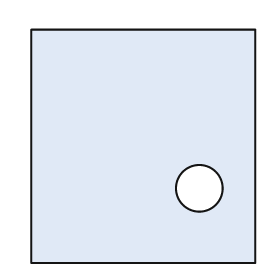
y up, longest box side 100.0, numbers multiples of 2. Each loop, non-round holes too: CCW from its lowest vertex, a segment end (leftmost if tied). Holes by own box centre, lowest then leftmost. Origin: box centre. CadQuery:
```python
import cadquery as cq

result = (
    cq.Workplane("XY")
    .moveTo(-48.0, -50.0)
    .lineTo(48.0, -50.0)
    .lineTo(48.0, 50.0)
    .lineTo(-48.0, 50.0)
    .close()
    .moveTo(24.0, -18.0)
    .circle(10.0)
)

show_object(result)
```